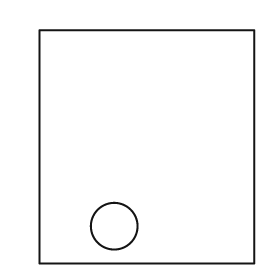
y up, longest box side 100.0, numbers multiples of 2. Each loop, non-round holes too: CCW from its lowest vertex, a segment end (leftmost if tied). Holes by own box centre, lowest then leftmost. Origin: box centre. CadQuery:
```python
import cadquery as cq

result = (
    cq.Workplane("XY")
    .moveTo(-46.0, -50.0)
    .lineTo(46.0, -50.0)
    .lineTo(46.0, 50.0)
    .lineTo(-46.0, 50.0)
    .close()
    .moveTo(-14.0, -34.0)
    .circle(10.0)
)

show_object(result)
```